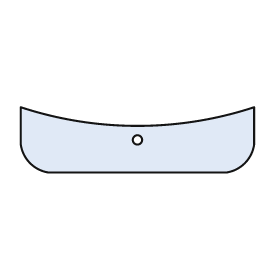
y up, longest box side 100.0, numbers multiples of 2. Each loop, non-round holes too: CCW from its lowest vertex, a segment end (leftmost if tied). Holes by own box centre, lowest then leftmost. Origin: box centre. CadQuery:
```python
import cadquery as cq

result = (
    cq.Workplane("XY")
    .moveTo(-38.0, -14.0)
    .lineTo(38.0, -14.0)
    .threePointArc((46.0, -10.0), (50.0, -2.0))
    .lineTo(50.0, 14.0)
    .threePointArc((0.0, 6.0), (-50.0, 14.0))
    .lineTo(-50.0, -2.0)
    .threePointArc((-46.0, -10.0), (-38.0, -14.0))
    .close()
    .moveTo(0.0, 0.0)
    .circle(2.0)
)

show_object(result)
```